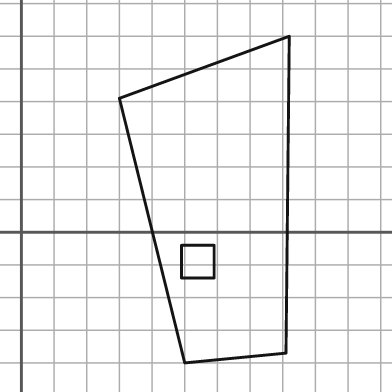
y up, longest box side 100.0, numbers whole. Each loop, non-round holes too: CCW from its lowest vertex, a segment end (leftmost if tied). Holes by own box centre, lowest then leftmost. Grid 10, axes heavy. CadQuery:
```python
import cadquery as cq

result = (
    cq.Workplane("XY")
    .moveTo(50.0, -40.0)
    .lineTo(81.0, -37.0)
    .lineTo(82.0, 60.0)
    .lineTo(30.0, 41.0)
    .close()
    .moveTo(49.0, -14.0)
    .lineTo(59.0, -14.0)
    .lineTo(59.0, -4.0)
    .lineTo(49.0, -4.0)
    .close()
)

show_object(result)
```